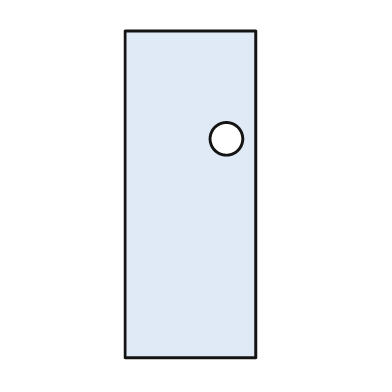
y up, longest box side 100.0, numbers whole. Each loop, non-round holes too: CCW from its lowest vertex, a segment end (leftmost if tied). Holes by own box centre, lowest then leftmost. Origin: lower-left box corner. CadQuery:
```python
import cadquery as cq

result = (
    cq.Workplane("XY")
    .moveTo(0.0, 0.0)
    .lineTo(40.0, 0.0)
    .lineTo(40.0, 100.0)
    .lineTo(0.0, 100.0)
    .close()
    .moveTo(31.0, 67.0)
    .circle(5.0)
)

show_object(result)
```